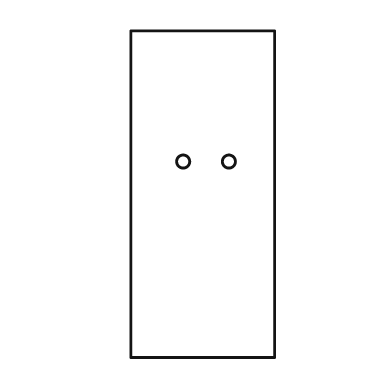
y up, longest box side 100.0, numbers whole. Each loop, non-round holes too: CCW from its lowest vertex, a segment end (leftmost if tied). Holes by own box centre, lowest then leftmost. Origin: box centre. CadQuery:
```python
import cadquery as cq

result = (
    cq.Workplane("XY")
    .moveTo(-22.0, -50.0)
    .lineTo(22.0, -50.0)
    .lineTo(22.0, 50.0)
    .lineTo(-22.0, 50.0)
    .close()
    .moveTo(-6.0, 10.0)
    .circle(2.0)
    .moveTo(8.0, 10.0)
    .circle(2.0)
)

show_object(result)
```